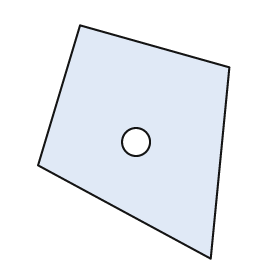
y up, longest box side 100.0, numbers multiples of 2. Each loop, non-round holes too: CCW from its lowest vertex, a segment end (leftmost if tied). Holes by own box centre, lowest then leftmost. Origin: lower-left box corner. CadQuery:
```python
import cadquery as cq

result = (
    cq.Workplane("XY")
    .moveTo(74.0, 0.0)
    .lineTo(82.0, 82.0)
    .lineTo(18.0, 100.0)
    .lineTo(0.0, 40.0)
    .close()
    .moveTo(42.0, 50.0)
    .circle(6.0)
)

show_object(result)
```